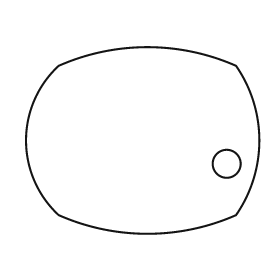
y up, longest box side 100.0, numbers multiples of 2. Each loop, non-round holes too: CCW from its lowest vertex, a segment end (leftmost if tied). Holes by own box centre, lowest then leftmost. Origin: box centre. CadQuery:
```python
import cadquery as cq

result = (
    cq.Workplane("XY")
    .moveTo(-36.0, -32.0)
    .threePointArc((2.0, -40.0), (40.0, -32.0))
    .threePointArc((50.0, 0.0), (40.0, 32.0))
    .threePointArc((2.0, 40.0), (-36.0, 32.0))
    .threePointArc((-50.0, 0.0), (-36.0, -32.0))
    .close()
    .moveTo(36.0, -10.0)
    .circle(6.0)
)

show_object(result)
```